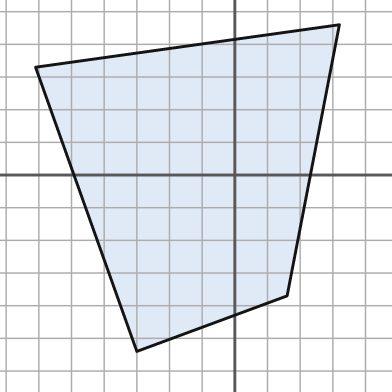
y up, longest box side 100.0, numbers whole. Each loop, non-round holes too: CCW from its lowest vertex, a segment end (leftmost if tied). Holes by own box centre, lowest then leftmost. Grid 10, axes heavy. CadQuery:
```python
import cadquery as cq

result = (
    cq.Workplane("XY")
    .moveTo(-30.0, -54.0)
    .lineTo(16.0, -37.0)
    .lineTo(32.0, 46.0)
    .lineTo(-61.0, 33.0)
    .close()
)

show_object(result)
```